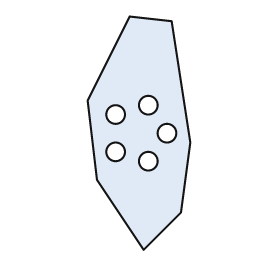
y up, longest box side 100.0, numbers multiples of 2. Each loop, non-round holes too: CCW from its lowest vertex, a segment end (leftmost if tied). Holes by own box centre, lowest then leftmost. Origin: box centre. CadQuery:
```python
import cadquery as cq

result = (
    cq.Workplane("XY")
    .moveTo(2.0, -50.0)
    .lineTo(18.0, -34.0)
    .lineTo(22.0, -4.0)
    .lineTo(14.0, 48.0)
    .lineTo(-4.0, 50.0)
    .lineTo(-22.0, 14.0)
    .lineTo(-18.0, -20.0)
    .close()
    .moveTo(4.0, -12.0)
    .circle(4.0)
    .moveTo(-10.0, -8.0)
    .circle(4.0)
    .moveTo(12.0, 0.0)
    .circle(4.0)
    .moveTo(-10.0, 8.0)
    .circle(4.0)
    .moveTo(4.0, 12.0)
    .circle(4.0)
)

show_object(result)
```